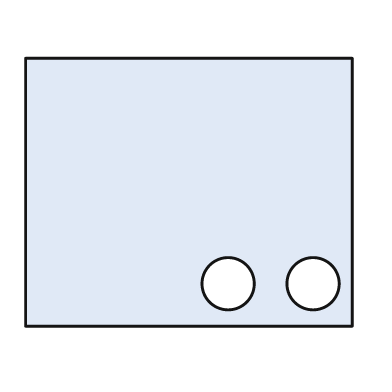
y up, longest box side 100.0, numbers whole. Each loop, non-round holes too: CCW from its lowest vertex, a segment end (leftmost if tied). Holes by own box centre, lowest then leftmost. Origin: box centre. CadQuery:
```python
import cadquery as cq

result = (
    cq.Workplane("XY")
    .moveTo(-50.0, -41.0)
    .lineTo(50.0, -41.0)
    .lineTo(50.0, 41.0)
    .lineTo(-50.0, 41.0)
    .close()
    .moveTo(12.0, -28.0)
    .circle(8.0)
    .moveTo(38.0, -28.0)
    .circle(8.0)
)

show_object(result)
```